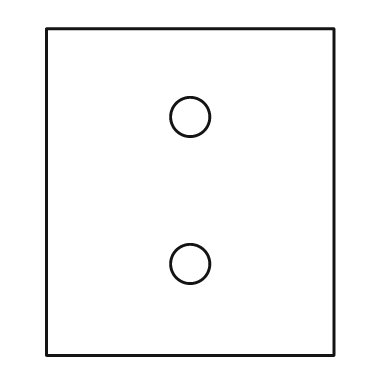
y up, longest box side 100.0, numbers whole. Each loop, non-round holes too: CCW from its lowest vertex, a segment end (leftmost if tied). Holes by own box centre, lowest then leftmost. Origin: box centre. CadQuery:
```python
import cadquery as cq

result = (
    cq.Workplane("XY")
    .moveTo(-44.0, -50.0)
    .lineTo(44.0, -50.0)
    .lineTo(44.0, 50.0)
    .lineTo(-44.0, 50.0)
    .close()
    .moveTo(0.0, -22.0)
    .circle(6.0)
    .moveTo(0.0, 23.0)
    .circle(6.0)
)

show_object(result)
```